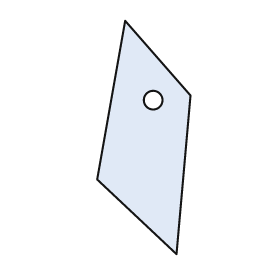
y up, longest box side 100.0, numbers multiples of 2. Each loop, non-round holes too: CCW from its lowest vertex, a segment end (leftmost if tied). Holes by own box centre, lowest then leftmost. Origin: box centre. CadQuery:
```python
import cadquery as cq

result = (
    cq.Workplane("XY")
    .moveTo(14.0, -50.0)
    .lineTo(20.0, 18.0)
    .lineTo(-8.0, 50.0)
    .lineTo(-20.0, -18.0)
    .close()
    .moveTo(4.0, 16.0)
    .circle(4.0)
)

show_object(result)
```